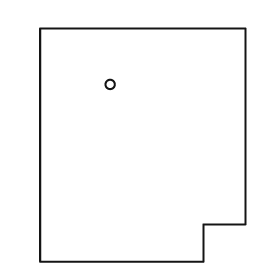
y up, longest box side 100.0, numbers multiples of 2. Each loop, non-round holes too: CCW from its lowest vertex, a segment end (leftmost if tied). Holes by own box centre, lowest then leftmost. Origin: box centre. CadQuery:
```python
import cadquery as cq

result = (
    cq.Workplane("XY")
    .moveTo(-44.0, -50.0)
    .lineTo(26.0, -50.0)
    .lineTo(26.0, -34.0)
    .lineTo(44.0, -34.0)
    .lineTo(44.0, 50.0)
    .lineTo(-44.0, 50.0)
    .close()
    .moveTo(-14.0, 26.0)
    .circle(2.0)
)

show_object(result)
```